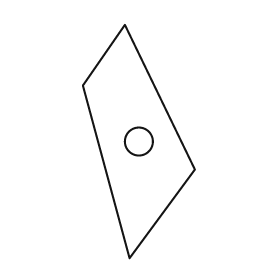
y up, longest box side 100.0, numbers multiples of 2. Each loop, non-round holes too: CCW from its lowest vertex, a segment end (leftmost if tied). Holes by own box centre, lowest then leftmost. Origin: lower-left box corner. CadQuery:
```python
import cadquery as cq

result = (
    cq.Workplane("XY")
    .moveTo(20.0, 0.0)
    .lineTo(48.0, 38.0)
    .lineTo(18.0, 100.0)
    .lineTo(0.0, 74.0)
    .close()
    .moveTo(24.0, 50.0)
    .circle(6.0)
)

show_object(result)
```